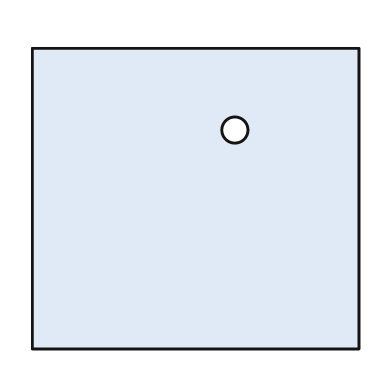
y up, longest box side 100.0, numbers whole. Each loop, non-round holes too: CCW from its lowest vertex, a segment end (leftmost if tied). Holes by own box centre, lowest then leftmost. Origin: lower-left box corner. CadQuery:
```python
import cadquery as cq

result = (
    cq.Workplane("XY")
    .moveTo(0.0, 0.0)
    .lineTo(100.0, 0.0)
    .lineTo(100.0, 92.0)
    .lineTo(0.0, 92.0)
    .close()
    .moveTo(62.0, 67.0)
    .circle(4.0)
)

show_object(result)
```